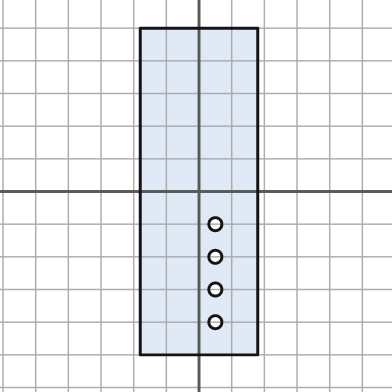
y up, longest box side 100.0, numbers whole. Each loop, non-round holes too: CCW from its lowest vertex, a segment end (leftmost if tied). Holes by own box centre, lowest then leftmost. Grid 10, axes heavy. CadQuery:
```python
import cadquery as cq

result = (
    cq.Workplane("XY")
    .moveTo(-18.0, -50.0)
    .lineTo(18.0, -50.0)
    .lineTo(18.0, 50.0)
    .lineTo(-18.0, 50.0)
    .close()
    .moveTo(5.0, -40.0)
    .circle(2.0)
    .moveTo(5.0, -30.0)
    .circle(2.0)
    .moveTo(5.0, -20.0)
    .circle(2.0)
    .moveTo(5.0, -10.0)
    .circle(2.0)
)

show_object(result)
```